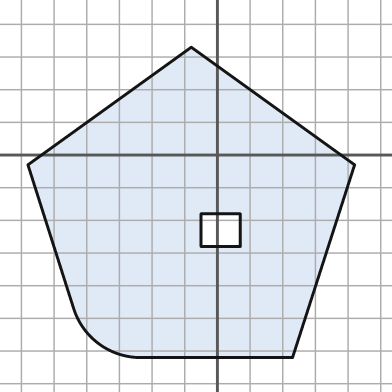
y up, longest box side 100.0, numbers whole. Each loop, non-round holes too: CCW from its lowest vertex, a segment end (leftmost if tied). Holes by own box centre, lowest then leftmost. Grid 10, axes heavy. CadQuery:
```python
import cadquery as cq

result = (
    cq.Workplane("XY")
    .moveTo(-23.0, -62.0)
    .lineTo(23.0, -62.0)
    .lineTo(42.0, -3.0)
    .lineTo(-8.0, 33.0)
    .lineTo(-58.0, -3.0)
    .lineTo(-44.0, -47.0)
    .threePointArc((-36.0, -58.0), (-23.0, -62.0))
    .close()
    .moveTo(-5.0, -28.0)
    .lineTo(7.0, -28.0)
    .lineTo(7.0, -18.0)
    .lineTo(-5.0, -18.0)
    .close()
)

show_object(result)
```